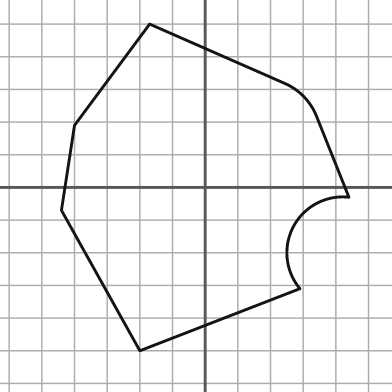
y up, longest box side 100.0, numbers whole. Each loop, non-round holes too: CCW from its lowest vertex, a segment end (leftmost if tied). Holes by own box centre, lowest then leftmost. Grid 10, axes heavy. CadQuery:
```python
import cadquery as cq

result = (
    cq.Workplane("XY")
    .moveTo(-20.0, -50.0)
    .lineTo(29.0, -31.0)
    .threePointArc((27.0, -12.0), (44.0, -3.0))
    .lineTo(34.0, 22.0)
    .threePointArc((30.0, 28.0), (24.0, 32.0))
    .lineTo(-17.0, 50.0)
    .lineTo(-40.0, 19.0)
    .lineTo(-44.0, -7.0)
    .close()
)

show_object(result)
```